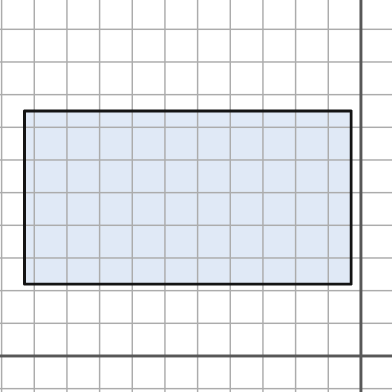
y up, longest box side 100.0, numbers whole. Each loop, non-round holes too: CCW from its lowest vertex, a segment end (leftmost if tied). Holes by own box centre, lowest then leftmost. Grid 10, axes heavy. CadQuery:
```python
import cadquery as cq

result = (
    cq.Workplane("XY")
    .moveTo(-103.0, 22.0)
    .lineTo(-3.0, 22.0)
    .lineTo(-3.0, 75.0)
    .lineTo(-103.0, 75.0)
    .close()
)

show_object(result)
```